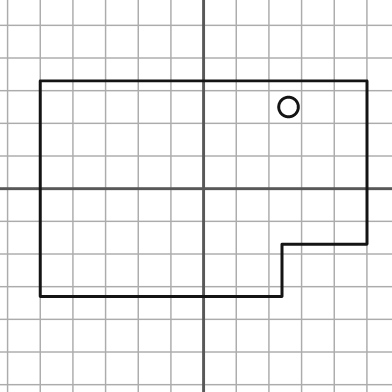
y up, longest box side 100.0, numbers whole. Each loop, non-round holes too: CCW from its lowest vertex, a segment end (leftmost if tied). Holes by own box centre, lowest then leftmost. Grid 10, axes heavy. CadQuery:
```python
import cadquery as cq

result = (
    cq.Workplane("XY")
    .moveTo(-50.0, -33.0)
    .lineTo(24.0, -33.0)
    .lineTo(24.0, -17.0)
    .lineTo(50.0, -17.0)
    .lineTo(50.0, 33.0)
    .lineTo(-50.0, 33.0)
    .close()
    .moveTo(26.0, 25.0)
    .circle(3.0)
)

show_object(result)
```